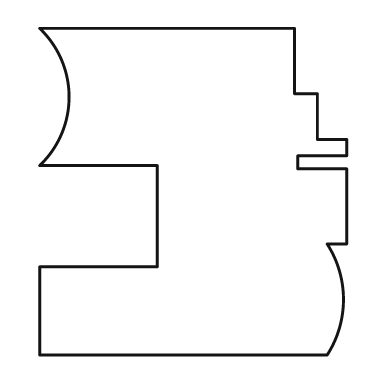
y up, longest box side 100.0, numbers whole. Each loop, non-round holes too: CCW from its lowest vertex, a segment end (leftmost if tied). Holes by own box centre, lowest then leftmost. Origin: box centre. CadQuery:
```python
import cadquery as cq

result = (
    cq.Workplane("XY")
    .moveTo(-47.0, -50.0)
    .lineTo(41.0, -50.0)
    .threePointArc((46.0, -33.0), (41.0, -16.0))
    .lineTo(47.0, -16.0)
    .lineTo(47.0, 7.0)
    .lineTo(32.0, 7.0)
    .lineTo(32.0, 11.0)
    .lineTo(47.0, 11.0)
    .lineTo(47.0, 16.0)
    .lineTo(38.0, 16.0)
    .lineTo(38.0, 30.0)
    .lineTo(31.0, 30.0)
    .lineTo(31.0, 50.0)
    .lineTo(-47.0, 50.0)
    .threePointArc((-38.0, 29.0), (-47.0, 8.0))
    .lineTo(-11.0, 8.0)
    .lineTo(-11.0, -23.0)
    .lineTo(-47.0, -23.0)
    .close()
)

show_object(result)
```